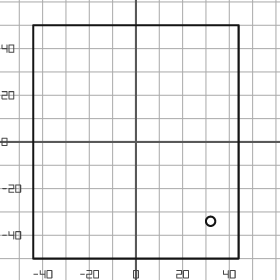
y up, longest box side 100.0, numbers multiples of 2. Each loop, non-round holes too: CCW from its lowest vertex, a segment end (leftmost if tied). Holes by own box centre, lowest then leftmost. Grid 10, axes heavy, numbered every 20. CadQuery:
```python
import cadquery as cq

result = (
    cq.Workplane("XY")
    .moveTo(-44.0, -50.0)
    .lineTo(44.0, -50.0)
    .lineTo(44.0, 50.0)
    .lineTo(-44.0, 50.0)
    .close()
    .moveTo(32.0, -34.0)
    .circle(2.0)
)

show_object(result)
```